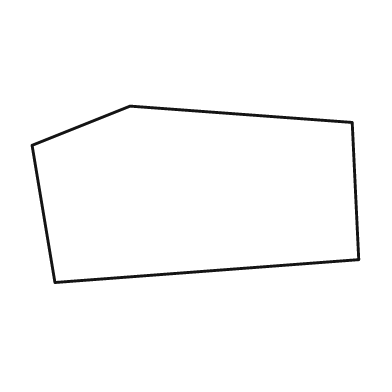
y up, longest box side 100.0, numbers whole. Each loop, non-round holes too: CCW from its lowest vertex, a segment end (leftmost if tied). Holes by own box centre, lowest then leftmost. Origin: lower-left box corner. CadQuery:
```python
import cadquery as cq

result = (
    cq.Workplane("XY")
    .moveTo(7.0, 0.0)
    .lineTo(100.0, 7.0)
    .lineTo(98.0, 49.0)
    .lineTo(30.0, 54.0)
    .lineTo(0.0, 42.0)
    .close()
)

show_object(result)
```